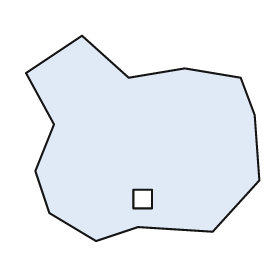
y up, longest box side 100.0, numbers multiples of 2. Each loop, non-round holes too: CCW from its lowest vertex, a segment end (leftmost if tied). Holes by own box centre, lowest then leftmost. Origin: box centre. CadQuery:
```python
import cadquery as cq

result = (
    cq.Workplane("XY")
    .moveTo(-20.0, -44.0)
    .lineTo(-2.0, -38.0)
    .lineTo(30.0, -40.0)
    .lineTo(50.0, -18.0)
    .lineTo(48.0, 10.0)
    .lineTo(42.0, 26.0)
    .lineTo(18.0, 30.0)
    .lineTo(-6.0, 26.0)
    .lineTo(-26.0, 44.0)
    .lineTo(-50.0, 28.0)
    .lineTo(-38.0, 6.0)
    .lineTo(-46.0, -14.0)
    .lineTo(-40.0, -32.0)
    .close()
    .moveTo(-4.0, -30.0)
    .lineTo(4.0, -30.0)
    .lineTo(4.0, -22.0)
    .lineTo(-4.0, -22.0)
    .close()
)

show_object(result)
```